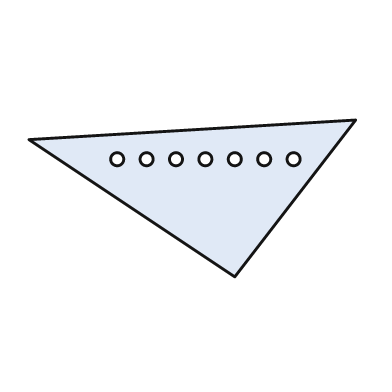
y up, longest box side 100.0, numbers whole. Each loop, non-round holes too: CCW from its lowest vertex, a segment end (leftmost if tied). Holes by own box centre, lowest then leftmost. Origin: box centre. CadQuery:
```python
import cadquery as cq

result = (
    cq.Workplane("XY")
    .moveTo(13.0, -24.0)
    .lineTo(50.0, 24.0)
    .lineTo(-50.0, 18.0)
    .close()
    .moveTo(-23.0, 12.0)
    .circle(2.0)
    .moveTo(-14.0, 12.0)
    .circle(2.0)
    .moveTo(-5.0, 12.0)
    .circle(2.0)
    .moveTo(4.0, 12.0)
    .circle(2.0)
    .moveTo(13.0, 12.0)
    .circle(2.0)
    .moveTo(22.0, 12.0)
    .circle(2.0)
    .moveTo(31.0, 12.0)
    .circle(2.0)
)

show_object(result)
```